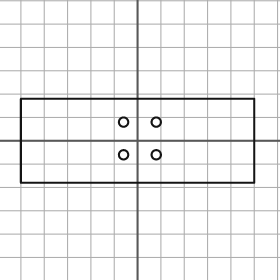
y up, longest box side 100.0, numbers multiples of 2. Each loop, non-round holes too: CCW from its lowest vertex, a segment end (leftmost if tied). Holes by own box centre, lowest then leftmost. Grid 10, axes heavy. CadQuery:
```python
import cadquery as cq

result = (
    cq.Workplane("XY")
    .moveTo(-50.0, -18.0)
    .lineTo(50.0, -18.0)
    .lineTo(50.0, 18.0)
    .lineTo(-50.0, 18.0)
    .close()
    .moveTo(-6.0, -6.0)
    .circle(2.0)
    .moveTo(8.0, -6.0)
    .circle(2.0)
    .moveTo(-6.0, 8.0)
    .circle(2.0)
    .moveTo(8.0, 8.0)
    .circle(2.0)
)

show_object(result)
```